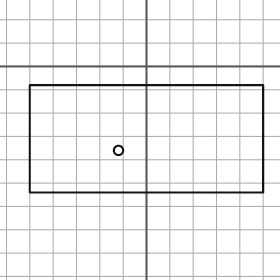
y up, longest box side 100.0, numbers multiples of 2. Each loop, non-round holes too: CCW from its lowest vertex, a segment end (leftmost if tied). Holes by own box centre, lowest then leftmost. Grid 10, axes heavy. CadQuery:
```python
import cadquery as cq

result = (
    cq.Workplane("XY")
    .moveTo(-50.0, -54.0)
    .lineTo(50.0, -54.0)
    .lineTo(50.0, -8.0)
    .lineTo(-50.0, -8.0)
    .close()
    .moveTo(-12.0, -36.0)
    .circle(2.0)
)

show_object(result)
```